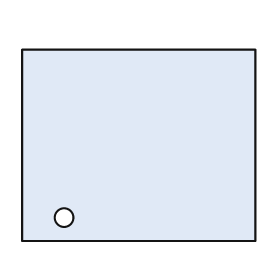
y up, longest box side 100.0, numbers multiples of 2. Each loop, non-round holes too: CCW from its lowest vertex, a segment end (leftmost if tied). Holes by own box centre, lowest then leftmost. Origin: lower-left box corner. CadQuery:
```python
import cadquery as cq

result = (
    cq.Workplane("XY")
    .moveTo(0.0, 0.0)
    .lineTo(100.0, 0.0)
    .lineTo(100.0, 82.0)
    .lineTo(0.0, 82.0)
    .close()
    .moveTo(18.0, 10.0)
    .circle(4.0)
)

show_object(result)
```